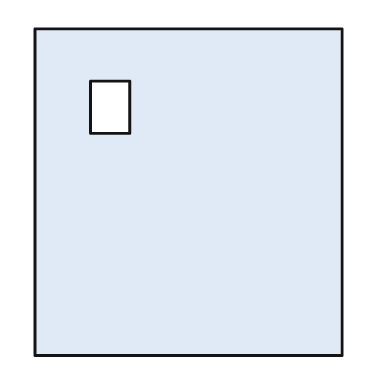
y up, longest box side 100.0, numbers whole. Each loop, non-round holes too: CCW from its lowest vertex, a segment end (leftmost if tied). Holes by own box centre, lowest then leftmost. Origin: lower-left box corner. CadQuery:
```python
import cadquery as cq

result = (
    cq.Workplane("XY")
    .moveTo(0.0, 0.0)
    .lineTo(94.0, 0.0)
    .lineTo(94.0, 100.0)
    .lineTo(0.0, 100.0)
    .close()
    .moveTo(17.0, 68.0)
    .lineTo(29.0, 68.0)
    .lineTo(29.0, 84.0)
    .lineTo(17.0, 84.0)
    .close()
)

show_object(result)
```